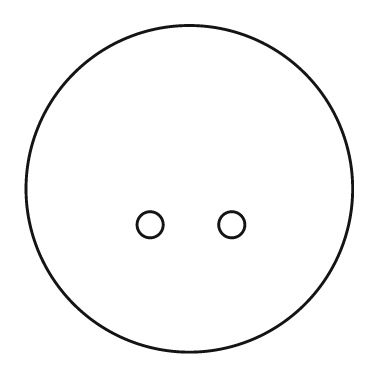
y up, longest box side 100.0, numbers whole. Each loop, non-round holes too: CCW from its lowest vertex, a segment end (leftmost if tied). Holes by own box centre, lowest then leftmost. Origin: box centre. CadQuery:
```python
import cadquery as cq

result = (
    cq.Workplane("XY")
    .moveTo(0.0, 0.0)
    .circle(50.0)
    .moveTo(-12.0, -11.0)
    .circle(4.0)
    .moveTo(13.0, -11.0)
    .circle(4.0)
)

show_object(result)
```